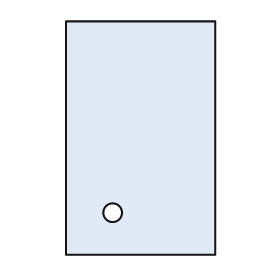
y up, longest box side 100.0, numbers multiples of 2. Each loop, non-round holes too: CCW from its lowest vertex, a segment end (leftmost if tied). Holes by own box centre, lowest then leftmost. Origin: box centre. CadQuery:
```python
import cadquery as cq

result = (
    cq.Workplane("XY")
    .moveTo(-32.0, -50.0)
    .lineTo(32.0, -50.0)
    .lineTo(32.0, 50.0)
    .lineTo(-32.0, 50.0)
    .close()
    .moveTo(-12.0, -32.0)
    .circle(4.0)
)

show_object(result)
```